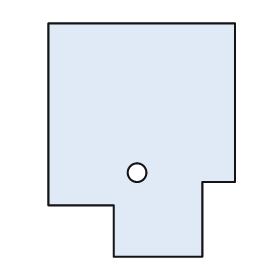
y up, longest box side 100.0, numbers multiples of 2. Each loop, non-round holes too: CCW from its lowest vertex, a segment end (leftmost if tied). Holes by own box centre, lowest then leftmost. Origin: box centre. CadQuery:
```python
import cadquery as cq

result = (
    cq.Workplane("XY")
    .moveTo(-12.0, -50.0)
    .lineTo(26.0, -50.0)
    .lineTo(26.0, -18.0)
    .lineTo(40.0, -18.0)
    .lineTo(40.0, 50.0)
    .lineTo(-40.0, 50.0)
    .lineTo(-40.0, -28.0)
    .lineTo(-12.0, -28.0)
    .close()
    .moveTo(-2.0, -14.0)
    .circle(4.0)
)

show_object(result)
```